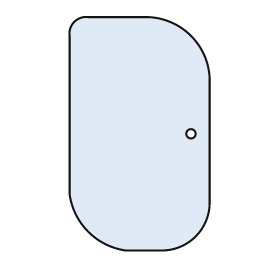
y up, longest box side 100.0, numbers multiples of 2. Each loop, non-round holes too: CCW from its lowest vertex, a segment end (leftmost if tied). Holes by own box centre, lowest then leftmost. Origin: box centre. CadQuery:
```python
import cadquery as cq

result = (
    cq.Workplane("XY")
    .moveTo(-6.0, -50.0)
    .lineTo(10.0, -50.0)
    .threePointArc((24.0, -44.0), (30.0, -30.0))
    .lineTo(30.0, 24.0)
    .threePointArc((22.0, 42.0), (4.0, 50.0))
    .lineTo(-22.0, 50.0)
    .threePointArc((-28.0, 48.0), (-30.0, 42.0))
    .lineTo(-30.0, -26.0)
    .threePointArc((-22.0, -42.0), (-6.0, -50.0))
    .close()
    .moveTo(22.0, 0.0)
    .circle(2.0)
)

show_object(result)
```